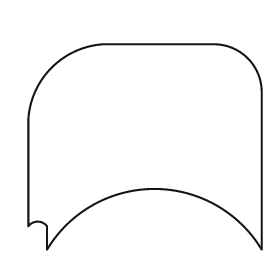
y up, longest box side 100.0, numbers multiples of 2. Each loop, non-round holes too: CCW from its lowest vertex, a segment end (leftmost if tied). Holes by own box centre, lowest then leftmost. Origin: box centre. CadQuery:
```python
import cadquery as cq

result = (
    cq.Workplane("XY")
    .moveTo(-42.0, -44.0)
    .threePointArc((4.0, -18.0), (50.0, -44.0))
    .lineTo(50.0, 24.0)
    .threePointArc((44.0, 38.0), (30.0, 44.0))
    .lineTo(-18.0, 44.0)
    .threePointArc((-40.0, 34.0), (-50.0, 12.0))
    .lineTo(-50.0, -34.0)
    .threePointArc((-46.0, -32.0), (-42.0, -34.0))
    .close()
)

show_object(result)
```